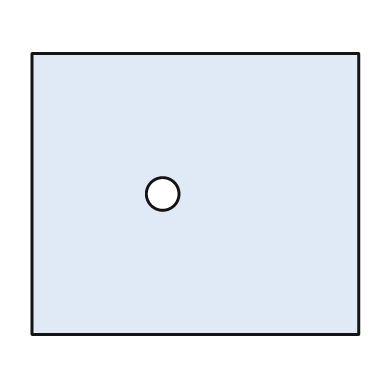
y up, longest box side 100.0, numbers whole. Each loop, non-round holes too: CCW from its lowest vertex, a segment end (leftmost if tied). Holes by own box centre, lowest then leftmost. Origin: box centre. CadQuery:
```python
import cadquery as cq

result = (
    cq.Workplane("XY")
    .moveTo(-50.0, -43.0)
    .lineTo(50.0, -43.0)
    .lineTo(50.0, 43.0)
    .lineTo(-50.0, 43.0)
    .close()
    .moveTo(-10.0, 0.0)
    .circle(5.0)
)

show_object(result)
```